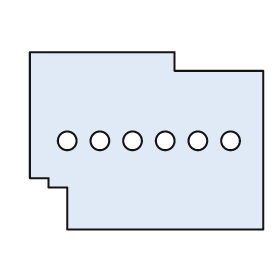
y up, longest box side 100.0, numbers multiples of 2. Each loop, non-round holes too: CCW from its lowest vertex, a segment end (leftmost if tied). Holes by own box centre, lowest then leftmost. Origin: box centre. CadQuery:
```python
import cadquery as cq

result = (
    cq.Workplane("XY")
    .moveTo(-34.0, -38.0)
    .lineTo(50.0, -38.0)
    .lineTo(50.0, 30.0)
    .lineTo(12.0, 30.0)
    .lineTo(12.0, 38.0)
    .lineTo(-50.0, 38.0)
    .lineTo(-50.0, -16.0)
    .lineTo(-42.0, -16.0)
    .lineTo(-42.0, -20.0)
    .lineTo(-34.0, -20.0)
    .close()
    .moveTo(-34.0, 0.0)
    .circle(4.0)
    .moveTo(-20.0, 0.0)
    .circle(4.0)
    .moveTo(-6.0, 0.0)
    .circle(4.0)
    .moveTo(8.0, 0.0)
    .circle(4.0)
    .moveTo(22.0, 0.0)
    .circle(4.0)
    .moveTo(36.0, 0.0)
    .circle(4.0)
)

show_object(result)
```